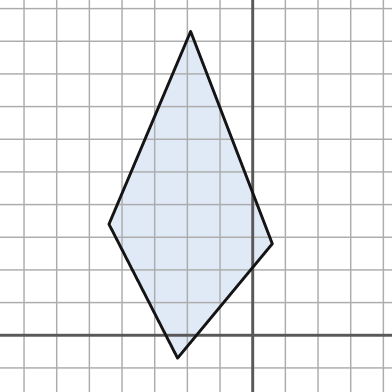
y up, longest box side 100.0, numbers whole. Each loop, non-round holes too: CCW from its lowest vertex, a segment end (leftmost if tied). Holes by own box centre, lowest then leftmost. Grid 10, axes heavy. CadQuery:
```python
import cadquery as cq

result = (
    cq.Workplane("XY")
    .moveTo(-23.0, -7.0)
    .lineTo(6.0, 28.0)
    .lineTo(-19.0, 93.0)
    .lineTo(-44.0, 34.0)
    .close()
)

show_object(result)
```